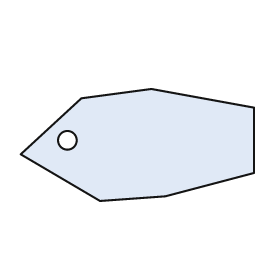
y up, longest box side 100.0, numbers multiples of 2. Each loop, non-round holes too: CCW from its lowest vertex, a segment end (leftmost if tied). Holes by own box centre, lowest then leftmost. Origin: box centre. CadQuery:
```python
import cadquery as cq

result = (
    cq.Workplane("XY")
    .moveTo(-16.0, -24.0)
    .lineTo(12.0, -22.0)
    .lineTo(50.0, -12.0)
    .lineTo(50.0, 16.0)
    .lineTo(6.0, 24.0)
    .lineTo(-24.0, 20.0)
    .lineTo(-50.0, -4.0)
    .close()
    .moveTo(-30.0, 2.0)
    .circle(4.0)
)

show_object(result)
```